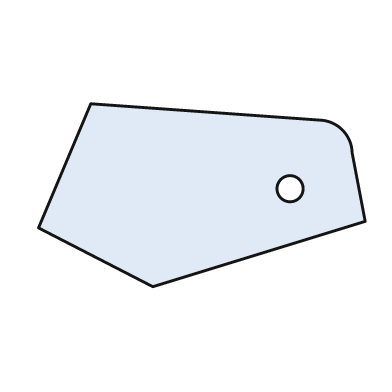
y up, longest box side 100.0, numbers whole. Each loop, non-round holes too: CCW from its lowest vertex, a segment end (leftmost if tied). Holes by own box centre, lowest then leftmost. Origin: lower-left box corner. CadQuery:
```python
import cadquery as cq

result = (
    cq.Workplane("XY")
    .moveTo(35.0, 0.0)
    .lineTo(100.0, 20.0)
    .lineTo(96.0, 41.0)
    .threePointArc((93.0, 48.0), (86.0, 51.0))
    .lineTo(16.0, 56.0)
    .lineTo(0.0, 18.0)
    .close()
    .moveTo(77.0, 30.0)
    .circle(4.0)
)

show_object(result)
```